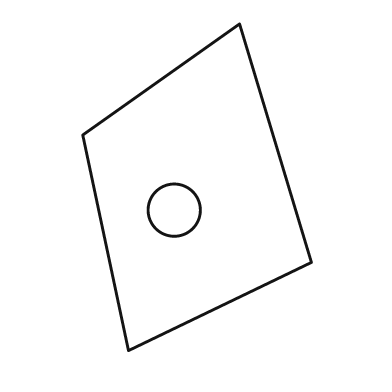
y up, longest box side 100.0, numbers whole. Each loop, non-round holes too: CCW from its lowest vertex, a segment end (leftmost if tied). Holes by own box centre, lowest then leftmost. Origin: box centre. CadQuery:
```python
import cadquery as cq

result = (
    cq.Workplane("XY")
    .moveTo(-21.0, -50.0)
    .lineTo(35.0, -23.0)
    .lineTo(13.0, 50.0)
    .lineTo(-35.0, 16.0)
    .close()
    .moveTo(-7.0, -7.0)
    .circle(8.0)
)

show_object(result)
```